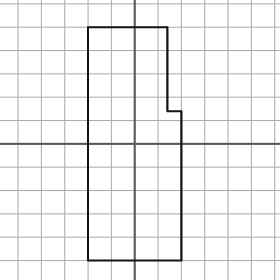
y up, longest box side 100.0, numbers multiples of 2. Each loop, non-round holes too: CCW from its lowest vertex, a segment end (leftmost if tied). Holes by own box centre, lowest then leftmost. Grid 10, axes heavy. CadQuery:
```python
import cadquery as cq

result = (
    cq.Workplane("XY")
    .moveTo(-20.0, -50.0)
    .lineTo(20.0, -50.0)
    .lineTo(20.0, 14.0)
    .lineTo(14.0, 14.0)
    .lineTo(14.0, 50.0)
    .lineTo(-20.0, 50.0)
    .close()
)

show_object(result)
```